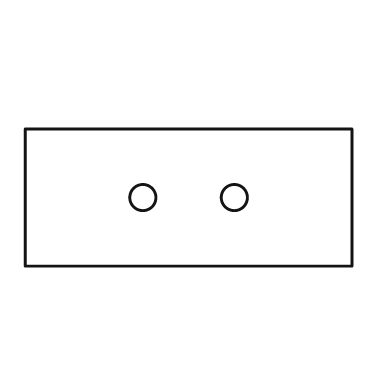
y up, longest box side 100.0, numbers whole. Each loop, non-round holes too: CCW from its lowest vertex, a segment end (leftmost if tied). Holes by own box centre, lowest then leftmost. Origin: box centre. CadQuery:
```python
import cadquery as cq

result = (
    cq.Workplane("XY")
    .moveTo(-50.0, -21.0)
    .lineTo(50.0, -21.0)
    .lineTo(50.0, 21.0)
    .lineTo(-50.0, 21.0)
    .close()
    .moveTo(-14.0, 0.0)
    .circle(4.0)
    .moveTo(14.0, 0.0)
    .circle(4.0)
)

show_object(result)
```